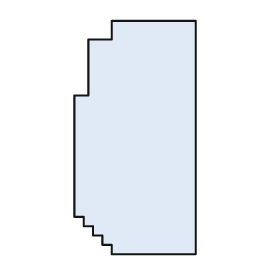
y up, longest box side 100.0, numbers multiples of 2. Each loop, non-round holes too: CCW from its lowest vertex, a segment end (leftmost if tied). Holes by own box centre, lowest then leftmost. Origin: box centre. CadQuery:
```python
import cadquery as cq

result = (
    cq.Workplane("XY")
    .moveTo(-10.0, -50.0)
    .lineTo(26.0, -50.0)
    .lineTo(26.0, 50.0)
    .lineTo(-10.0, 50.0)
    .lineTo(-10.0, 42.0)
    .lineTo(-20.0, 42.0)
    .lineTo(-20.0, 18.0)
    .lineTo(-26.0, 18.0)
    .lineTo(-26.0, -34.0)
    .lineTo(-22.0, -34.0)
    .lineTo(-22.0, -38.0)
    .lineTo(-18.0, -38.0)
    .lineTo(-18.0, -42.0)
    .lineTo(-14.0, -42.0)
    .lineTo(-14.0, -46.0)
    .lineTo(-10.0, -46.0)
    .close()
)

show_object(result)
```